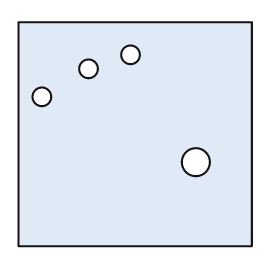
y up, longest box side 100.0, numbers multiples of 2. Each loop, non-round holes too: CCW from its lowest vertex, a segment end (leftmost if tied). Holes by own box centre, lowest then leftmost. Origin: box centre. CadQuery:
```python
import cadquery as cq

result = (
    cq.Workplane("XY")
    .moveTo(-50.0, -48.0)
    .lineTo(50.0, -48.0)
    .lineTo(50.0, 48.0)
    .lineTo(-50.0, 48.0)
    .close()
    .moveTo(26.0, -12.0)
    .circle(6.0)
    .moveTo(-40.0, 16.0)
    .circle(4.0)
    .moveTo(-20.0, 28.0)
    .circle(4.0)
    .moveTo(-2.0, 34.0)
    .circle(4.0)
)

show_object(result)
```